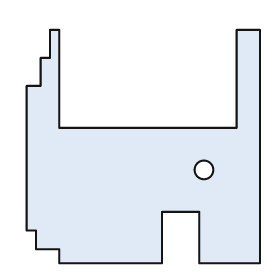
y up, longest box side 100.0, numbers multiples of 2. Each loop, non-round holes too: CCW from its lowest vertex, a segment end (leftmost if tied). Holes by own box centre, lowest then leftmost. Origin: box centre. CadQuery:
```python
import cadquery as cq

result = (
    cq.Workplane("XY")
    .moveTo(-36.0, -50.0)
    .lineTo(8.0, -50.0)
    .lineTo(8.0, -28.0)
    .lineTo(24.0, -28.0)
    .lineTo(24.0, -50.0)
    .lineTo(50.0, -50.0)
    .lineTo(50.0, 50.0)
    .lineTo(40.0, 50.0)
    .lineTo(40.0, 8.0)
    .lineTo(-36.0, 8.0)
    .lineTo(-36.0, 50.0)
    .lineTo(-40.0, 50.0)
    .lineTo(-40.0, 38.0)
    .lineTo(-44.0, 38.0)
    .lineTo(-44.0, 26.0)
    .lineTo(-50.0, 26.0)
    .lineTo(-50.0, -36.0)
    .lineTo(-46.0, -36.0)
    .lineTo(-46.0, -44.0)
    .lineTo(-36.0, -44.0)
    .close()
    .moveTo(26.0, -10.0)
    .circle(4.0)
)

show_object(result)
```